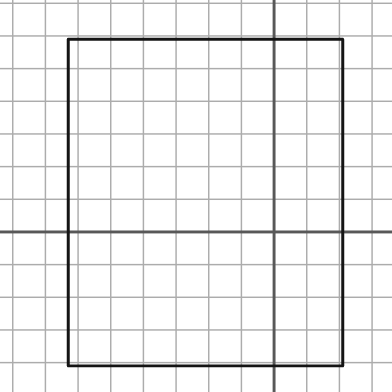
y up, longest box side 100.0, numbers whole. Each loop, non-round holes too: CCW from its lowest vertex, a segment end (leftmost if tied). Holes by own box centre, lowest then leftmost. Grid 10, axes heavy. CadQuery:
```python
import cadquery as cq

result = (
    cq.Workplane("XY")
    .moveTo(-63.0, -41.0)
    .lineTo(21.0, -41.0)
    .lineTo(21.0, 59.0)
    .lineTo(-63.0, 59.0)
    .close()
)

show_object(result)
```